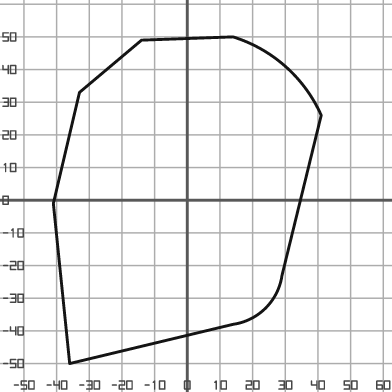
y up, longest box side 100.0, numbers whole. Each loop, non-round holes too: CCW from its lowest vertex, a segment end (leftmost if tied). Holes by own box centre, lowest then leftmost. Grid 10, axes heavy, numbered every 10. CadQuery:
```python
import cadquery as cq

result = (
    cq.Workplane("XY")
    .moveTo(-36.0, -50.0)
    .lineTo(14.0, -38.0)
    .threePointArc((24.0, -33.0), (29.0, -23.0))
    .lineTo(41.0, 26.0)
    .threePointArc((30.0, 41.0), (14.0, 50.0))
    .lineTo(-14.0, 49.0)
    .lineTo(-33.0, 33.0)
    .lineTo(-41.0, -1.0)
    .close()
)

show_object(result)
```